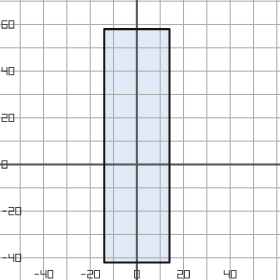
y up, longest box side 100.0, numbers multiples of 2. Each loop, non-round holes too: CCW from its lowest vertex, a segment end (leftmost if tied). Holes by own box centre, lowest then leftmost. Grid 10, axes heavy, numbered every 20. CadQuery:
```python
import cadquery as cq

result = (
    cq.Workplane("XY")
    .moveTo(-14.0, -42.0)
    .lineTo(14.0, -42.0)
    .lineTo(14.0, 58.0)
    .lineTo(-14.0, 58.0)
    .close()
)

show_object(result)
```